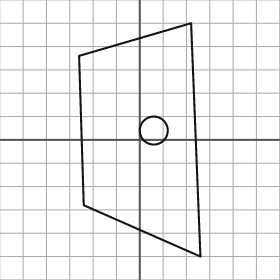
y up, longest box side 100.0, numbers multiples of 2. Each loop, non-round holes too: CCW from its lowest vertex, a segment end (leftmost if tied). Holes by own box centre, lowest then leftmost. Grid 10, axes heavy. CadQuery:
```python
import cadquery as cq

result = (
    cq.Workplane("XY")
    .moveTo(26.0, -50.0)
    .lineTo(22.0, 50.0)
    .lineTo(-26.0, 36.0)
    .lineTo(-24.0, -28.0)
    .close()
    .moveTo(6.0, 4.0)
    .circle(6.0)
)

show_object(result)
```